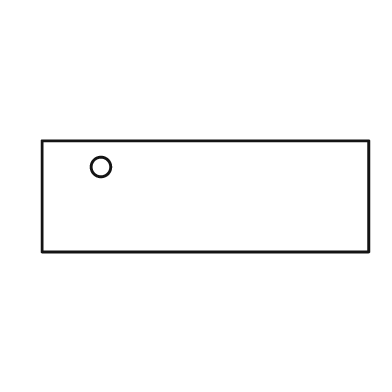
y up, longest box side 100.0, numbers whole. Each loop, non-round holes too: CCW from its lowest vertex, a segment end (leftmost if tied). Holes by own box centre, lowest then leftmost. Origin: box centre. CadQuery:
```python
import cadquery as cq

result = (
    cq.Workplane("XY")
    .moveTo(-50.0, -17.0)
    .lineTo(50.0, -17.0)
    .lineTo(50.0, 17.0)
    .lineTo(-50.0, 17.0)
    .close()
    .moveTo(-32.0, 9.0)
    .circle(3.0)
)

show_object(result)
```